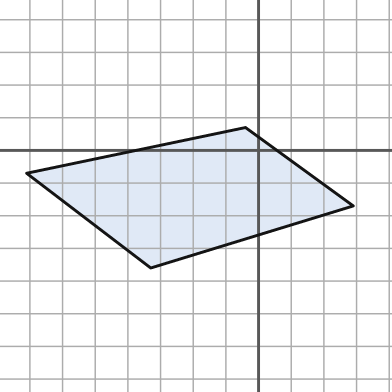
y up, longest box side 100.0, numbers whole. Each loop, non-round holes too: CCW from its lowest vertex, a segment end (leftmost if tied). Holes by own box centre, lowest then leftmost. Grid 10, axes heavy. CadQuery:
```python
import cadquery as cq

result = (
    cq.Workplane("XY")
    .moveTo(-33.0, -36.0)
    .lineTo(29.0, -17.0)
    .lineTo(-4.0, 7.0)
    .lineTo(-71.0, -7.0)
    .close()
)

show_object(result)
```